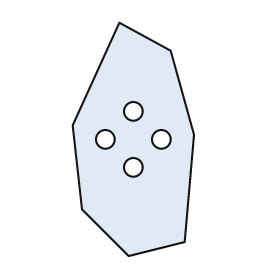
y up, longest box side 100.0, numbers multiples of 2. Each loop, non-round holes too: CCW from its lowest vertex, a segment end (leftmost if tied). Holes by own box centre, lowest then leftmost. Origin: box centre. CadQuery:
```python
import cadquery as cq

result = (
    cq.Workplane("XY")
    .moveTo(-2.0, -50.0)
    .lineTo(22.0, -44.0)
    .lineTo(26.0, 2.0)
    .lineTo(16.0, 38.0)
    .lineTo(-6.0, 50.0)
    .lineTo(-26.0, 6.0)
    .lineTo(-22.0, -30.0)
    .close()
    .moveTo(0.0, -12.0)
    .circle(4.0)
    .moveTo(-12.0, 0.0)
    .circle(4.0)
    .moveTo(12.0, 0.0)
    .circle(4.0)
    .moveTo(0.0, 12.0)
    .circle(4.0)
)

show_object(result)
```